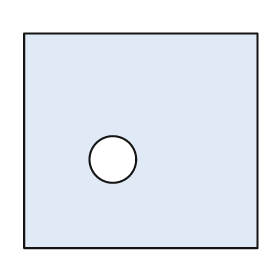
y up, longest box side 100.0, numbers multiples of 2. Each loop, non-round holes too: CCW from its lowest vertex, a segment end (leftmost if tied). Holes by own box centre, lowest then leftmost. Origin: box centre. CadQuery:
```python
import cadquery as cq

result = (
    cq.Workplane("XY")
    .moveTo(-50.0, -46.0)
    .lineTo(50.0, -46.0)
    .lineTo(50.0, 46.0)
    .lineTo(-50.0, 46.0)
    .close()
    .moveTo(-12.0, -8.0)
    .circle(10.0)
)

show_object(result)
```